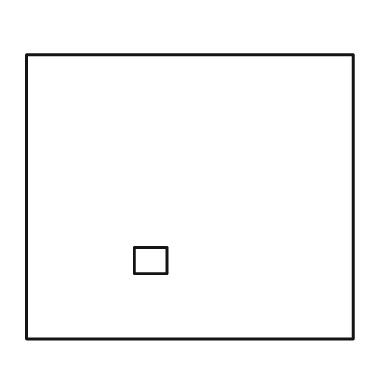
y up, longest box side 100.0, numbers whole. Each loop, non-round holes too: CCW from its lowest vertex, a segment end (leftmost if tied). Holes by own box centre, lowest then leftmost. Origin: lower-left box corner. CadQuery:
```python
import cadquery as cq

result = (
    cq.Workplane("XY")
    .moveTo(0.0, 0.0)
    .lineTo(100.0, 0.0)
    .lineTo(100.0, 87.0)
    .lineTo(0.0, 87.0)
    .close()
    .moveTo(33.0, 20.0)
    .lineTo(43.0, 20.0)
    .lineTo(43.0, 28.0)
    .lineTo(33.0, 28.0)
    .close()
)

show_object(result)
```